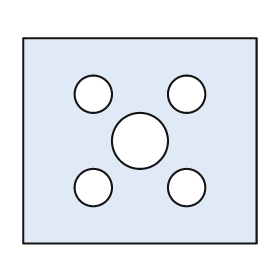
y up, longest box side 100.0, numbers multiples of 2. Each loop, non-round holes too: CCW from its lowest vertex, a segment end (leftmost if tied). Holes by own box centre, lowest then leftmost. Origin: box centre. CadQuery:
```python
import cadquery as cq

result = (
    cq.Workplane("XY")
    .moveTo(-50.0, -44.0)
    .lineTo(50.0, -44.0)
    .lineTo(50.0, 44.0)
    .lineTo(-50.0, 44.0)
    .close()
    .moveTo(-20.0, -20.0)
    .circle(8.0)
    .moveTo(20.0, -20.0)
    .circle(8.0)
    .moveTo(0.0, 0.0)
    .circle(12.0)
    .moveTo(-20.0, 20.0)
    .circle(8.0)
    .moveTo(20.0, 20.0)
    .circle(8.0)
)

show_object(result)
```